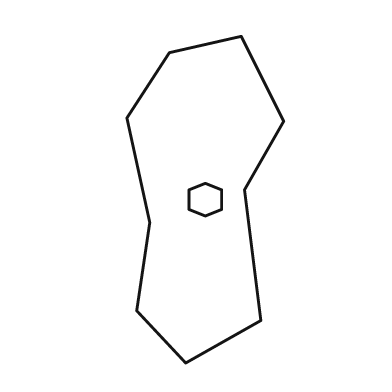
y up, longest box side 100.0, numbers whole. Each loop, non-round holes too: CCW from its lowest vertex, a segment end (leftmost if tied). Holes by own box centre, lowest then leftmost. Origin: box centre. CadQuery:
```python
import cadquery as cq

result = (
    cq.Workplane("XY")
    .moveTo(-6.0, -50.0)
    .lineTo(17.0, -37.0)
    .lineTo(12.0, 3.0)
    .lineTo(24.0, 24.0)
    .lineTo(11.0, 50.0)
    .lineTo(-11.0, 45.0)
    .lineTo(-24.0, 25.0)
    .lineTo(-17.0, -7.0)
    .lineTo(-21.0, -34.0)
    .close()
    .moveTo(0.0, -5.0)
    .lineTo(5.0, -3.0)
    .lineTo(5.0, 3.0)
    .lineTo(0.0, 5.0)
    .lineTo(-5.0, 3.0)
    .lineTo(-5.0, -3.0)
    .close()
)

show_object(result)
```